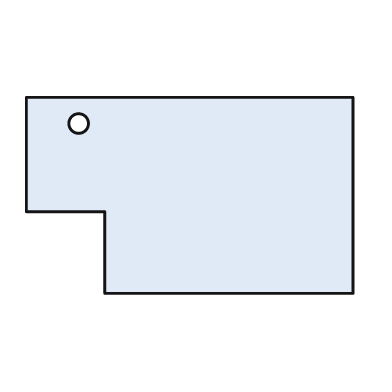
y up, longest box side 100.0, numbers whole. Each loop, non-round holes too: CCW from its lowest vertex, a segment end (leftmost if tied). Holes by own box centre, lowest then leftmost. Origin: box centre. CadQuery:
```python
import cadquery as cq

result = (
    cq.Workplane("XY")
    .moveTo(-26.0, -30.0)
    .lineTo(50.0, -30.0)
    .lineTo(50.0, 30.0)
    .lineTo(-50.0, 30.0)
    .lineTo(-50.0, -5.0)
    .lineTo(-26.0, -5.0)
    .close()
    .moveTo(-34.0, 22.0)
    .circle(3.0)
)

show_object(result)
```